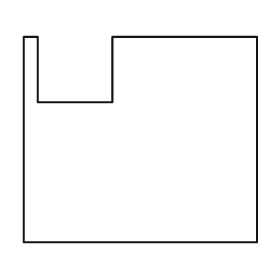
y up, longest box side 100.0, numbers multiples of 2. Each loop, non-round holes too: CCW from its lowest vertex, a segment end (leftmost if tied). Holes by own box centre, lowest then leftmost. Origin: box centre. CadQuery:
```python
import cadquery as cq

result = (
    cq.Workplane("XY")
    .moveTo(-50.0, -44.0)
    .lineTo(50.0, -44.0)
    .lineTo(50.0, 44.0)
    .lineTo(-12.0, 44.0)
    .lineTo(-12.0, 16.0)
    .lineTo(-44.0, 16.0)
    .lineTo(-44.0, 44.0)
    .lineTo(-50.0, 44.0)
    .close()
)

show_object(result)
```